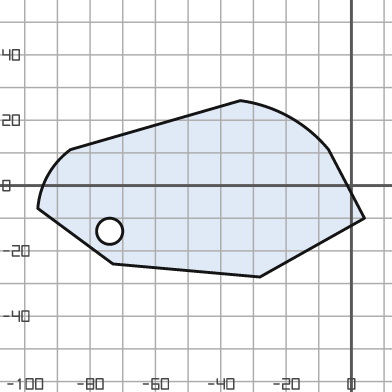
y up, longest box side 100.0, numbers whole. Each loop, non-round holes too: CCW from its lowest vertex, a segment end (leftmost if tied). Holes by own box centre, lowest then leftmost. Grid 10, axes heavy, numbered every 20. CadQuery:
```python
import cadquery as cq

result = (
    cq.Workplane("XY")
    .moveTo(-28.0, -28.0)
    .lineTo(4.0, -10.0)
    .lineTo(-7.0, 11.0)
    .threePointArc((-19.0, 21.0), (-34.0, 26.0))
    .lineTo(-86.0, 11.0)
    .threePointArc((-93.0, 3.0), (-96.0, -7.0))
    .lineTo(-73.0, -24.0)
    .close()
    .moveTo(-74.0, -14.0)
    .circle(4.0)
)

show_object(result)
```